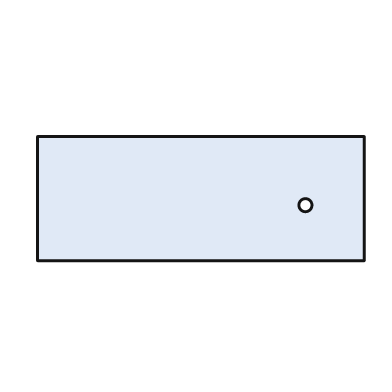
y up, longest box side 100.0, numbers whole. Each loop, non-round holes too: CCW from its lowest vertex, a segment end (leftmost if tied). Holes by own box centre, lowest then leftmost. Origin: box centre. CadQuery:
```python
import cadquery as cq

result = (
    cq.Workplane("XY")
    .moveTo(-50.0, -19.0)
    .lineTo(50.0, -19.0)
    .lineTo(50.0, 19.0)
    .lineTo(-50.0, 19.0)
    .close()
    .moveTo(32.0, -2.0)
    .circle(2.0)
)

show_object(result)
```